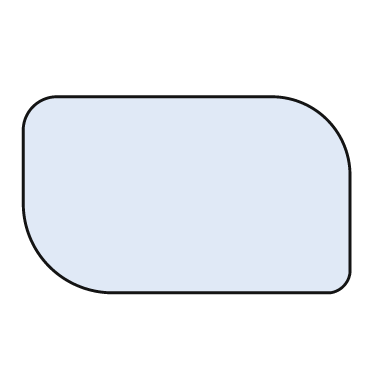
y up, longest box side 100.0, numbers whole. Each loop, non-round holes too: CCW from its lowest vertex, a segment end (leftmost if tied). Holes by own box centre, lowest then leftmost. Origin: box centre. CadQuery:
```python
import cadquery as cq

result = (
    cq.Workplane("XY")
    .moveTo(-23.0, -30.0)
    .lineTo(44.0, -30.0)
    .threePointArc((48.0, -28.0), (50.0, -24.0))
    .lineTo(50.0, 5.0)
    .threePointArc((43.0, 23.0), (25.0, 30.0))
    .lineTo(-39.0, 30.0)
    .threePointArc((-47.0, 27.0), (-50.0, 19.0))
    .lineTo(-50.0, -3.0)
    .threePointArc((-42.0, -22.0), (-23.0, -30.0))
    .close()
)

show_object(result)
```